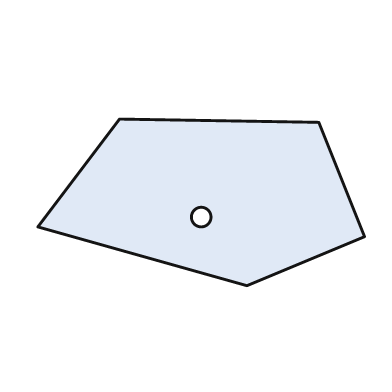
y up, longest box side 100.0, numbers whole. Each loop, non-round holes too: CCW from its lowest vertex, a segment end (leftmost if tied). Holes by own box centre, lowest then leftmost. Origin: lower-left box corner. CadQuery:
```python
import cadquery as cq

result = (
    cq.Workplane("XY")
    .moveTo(64.0, 0.0)
    .lineTo(100.0, 15.0)
    .lineTo(86.0, 50.0)
    .lineTo(25.0, 51.0)
    .lineTo(0.0, 18.0)
    .close()
    .moveTo(50.0, 21.0)
    .circle(3.0)
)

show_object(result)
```